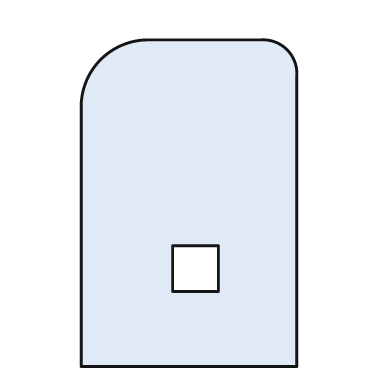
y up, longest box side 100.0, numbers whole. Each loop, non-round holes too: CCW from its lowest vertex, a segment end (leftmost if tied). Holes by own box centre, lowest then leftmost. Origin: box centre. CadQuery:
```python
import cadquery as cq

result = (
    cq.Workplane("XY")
    .moveTo(-33.0, -50.0)
    .lineTo(33.0, -50.0)
    .lineTo(33.0, 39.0)
    .threePointArc((30.0, 47.0), (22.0, 50.0))
    .lineTo(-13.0, 50.0)
    .threePointArc((-27.0, 44.0), (-33.0, 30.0))
    .close()
    .moveTo(-5.0, -27.0)
    .lineTo(9.0, -27.0)
    .lineTo(9.0, -13.0)
    .lineTo(-5.0, -13.0)
    .close()
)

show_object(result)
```